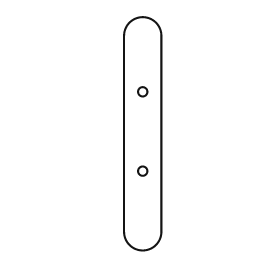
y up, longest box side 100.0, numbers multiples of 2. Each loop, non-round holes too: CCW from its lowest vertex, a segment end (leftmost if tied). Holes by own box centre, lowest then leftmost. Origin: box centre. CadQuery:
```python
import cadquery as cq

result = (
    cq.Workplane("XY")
    .moveTo(-8.0, -42.0)
    .threePointArc((0.0, -50.0), (8.0, -42.0))
    .lineTo(8.0, 42.0)
    .threePointArc((0.0, 50.0), (-8.0, 42.0))
    .close()
    .moveTo(0.0, -16.0)
    .circle(2.0)
    .moveTo(0.0, 18.0)
    .circle(2.0)
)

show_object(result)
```